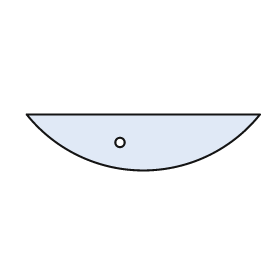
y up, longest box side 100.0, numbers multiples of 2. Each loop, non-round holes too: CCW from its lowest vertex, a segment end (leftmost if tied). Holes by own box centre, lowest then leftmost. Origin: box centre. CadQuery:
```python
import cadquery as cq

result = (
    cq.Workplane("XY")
    .moveTo(-50.0, 12.0)
    .threePointArc((0.0, -12.0), (50.0, 12.0))
    .close()
    .moveTo(-10.0, 0.0)
    .circle(2.0)
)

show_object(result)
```